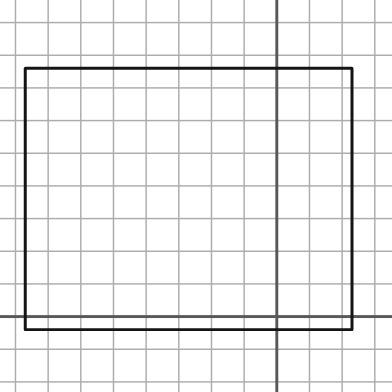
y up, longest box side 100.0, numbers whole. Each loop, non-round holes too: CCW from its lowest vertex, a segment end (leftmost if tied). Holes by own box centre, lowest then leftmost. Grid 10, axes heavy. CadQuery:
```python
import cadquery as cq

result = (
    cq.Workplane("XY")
    .moveTo(-77.0, -4.0)
    .lineTo(23.0, -4.0)
    .lineTo(23.0, 76.0)
    .lineTo(-77.0, 76.0)
    .close()
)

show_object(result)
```